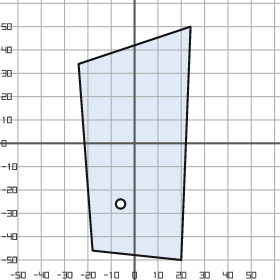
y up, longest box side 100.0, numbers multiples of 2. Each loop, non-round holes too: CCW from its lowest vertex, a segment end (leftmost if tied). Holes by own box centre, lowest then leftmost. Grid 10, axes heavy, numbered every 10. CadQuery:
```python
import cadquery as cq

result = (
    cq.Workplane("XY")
    .moveTo(20.0, -50.0)
    .lineTo(24.0, 50.0)
    .lineTo(-24.0, 34.0)
    .lineTo(-18.0, -46.0)
    .close()
    .moveTo(-6.0, -26.0)
    .circle(2.0)
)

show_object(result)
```